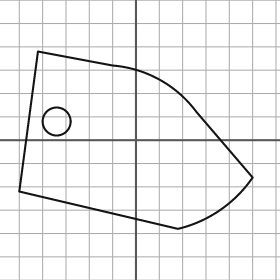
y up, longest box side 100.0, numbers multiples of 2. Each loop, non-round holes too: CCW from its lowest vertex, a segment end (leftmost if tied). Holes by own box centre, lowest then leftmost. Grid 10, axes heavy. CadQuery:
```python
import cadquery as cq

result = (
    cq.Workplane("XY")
    .moveTo(18.0, -38.0)
    .threePointArc((36.0, -30.0), (50.0, -16.0))
    .lineTo(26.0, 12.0)
    .threePointArc((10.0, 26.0), (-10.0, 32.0))
    .lineTo(-42.0, 38.0)
    .lineTo(-50.0, -22.0)
    .close()
    .moveTo(-34.0, 8.0)
    .circle(6.0)
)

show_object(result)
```